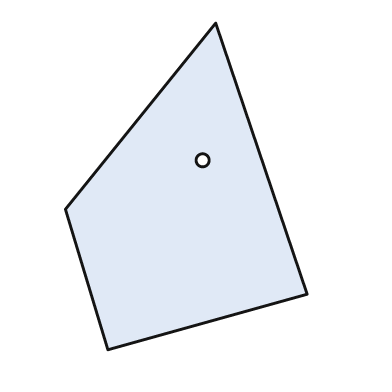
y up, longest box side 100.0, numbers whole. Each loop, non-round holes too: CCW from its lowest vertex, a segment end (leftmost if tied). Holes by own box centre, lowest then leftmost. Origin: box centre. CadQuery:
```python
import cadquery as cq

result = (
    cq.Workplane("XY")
    .moveTo(-24.0, -50.0)
    .lineTo(37.0, -33.0)
    .lineTo(9.0, 50.0)
    .lineTo(-37.0, -7.0)
    .close()
    .moveTo(5.0, 8.0)
    .circle(2.0)
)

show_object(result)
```